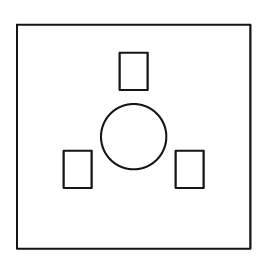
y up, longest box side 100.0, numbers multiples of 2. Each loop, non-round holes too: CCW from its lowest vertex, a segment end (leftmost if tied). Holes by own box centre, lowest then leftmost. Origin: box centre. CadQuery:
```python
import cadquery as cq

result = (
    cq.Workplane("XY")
    .moveTo(-50.0, -48.0)
    .lineTo(50.0, -48.0)
    .lineTo(50.0, 48.0)
    .lineTo(-50.0, 48.0)
    .close()
    .moveTo(-30.0, -22.0)
    .lineTo(-18.0, -22.0)
    .lineTo(-18.0, -6.0)
    .lineTo(-30.0, -6.0)
    .close()
    .moveTo(18.0, -22.0)
    .lineTo(30.0, -22.0)
    .lineTo(30.0, -6.0)
    .lineTo(18.0, -6.0)
    .close()
    .moveTo(0.0, 0.0)
    .circle(14.0)
    .moveTo(-6.0, 20.0)
    .lineTo(6.0, 20.0)
    .lineTo(6.0, 36.0)
    .lineTo(-6.0, 36.0)
    .close()
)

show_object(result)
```